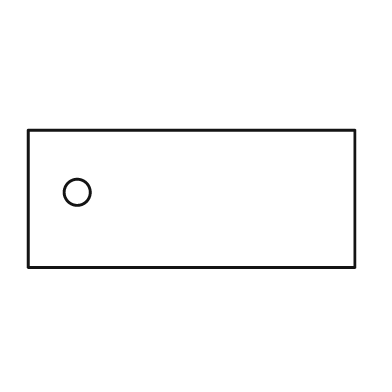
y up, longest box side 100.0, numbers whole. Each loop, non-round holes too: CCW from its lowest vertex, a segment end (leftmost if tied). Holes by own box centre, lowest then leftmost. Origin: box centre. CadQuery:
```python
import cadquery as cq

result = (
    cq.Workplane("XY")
    .moveTo(-50.0, -21.0)
    .lineTo(50.0, -21.0)
    .lineTo(50.0, 21.0)
    .lineTo(-50.0, 21.0)
    .close()
    .moveTo(-35.0, 2.0)
    .circle(4.0)
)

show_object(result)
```